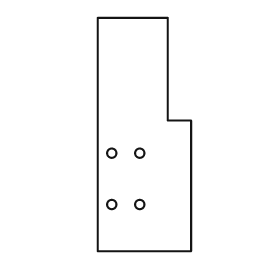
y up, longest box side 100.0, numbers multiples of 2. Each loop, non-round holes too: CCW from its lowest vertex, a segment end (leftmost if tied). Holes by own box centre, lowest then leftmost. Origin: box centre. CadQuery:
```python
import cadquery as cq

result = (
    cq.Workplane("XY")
    .moveTo(-20.0, -50.0)
    .lineTo(20.0, -50.0)
    .lineTo(20.0, 6.0)
    .lineTo(10.0, 6.0)
    .lineTo(10.0, 50.0)
    .lineTo(-20.0, 50.0)
    .close()
    .moveTo(-14.0, -30.0)
    .circle(2.0)
    .moveTo(-2.0, -30.0)
    .circle(2.0)
    .moveTo(-14.0, -8.0)
    .circle(2.0)
    .moveTo(-2.0, -8.0)
    .circle(2.0)
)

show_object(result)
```